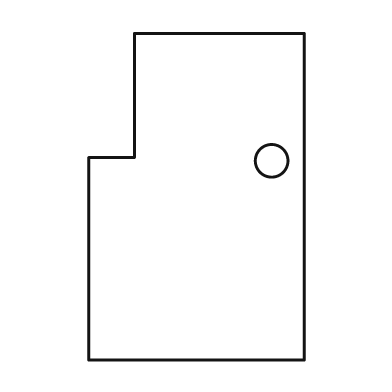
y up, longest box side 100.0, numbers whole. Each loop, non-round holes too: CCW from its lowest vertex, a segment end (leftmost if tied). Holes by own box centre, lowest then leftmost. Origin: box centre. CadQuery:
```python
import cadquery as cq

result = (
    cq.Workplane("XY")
    .moveTo(-33.0, -50.0)
    .lineTo(33.0, -50.0)
    .lineTo(33.0, 50.0)
    .lineTo(-19.0, 50.0)
    .lineTo(-19.0, 12.0)
    .lineTo(-33.0, 12.0)
    .close()
    .moveTo(23.0, 11.0)
    .circle(5.0)
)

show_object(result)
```